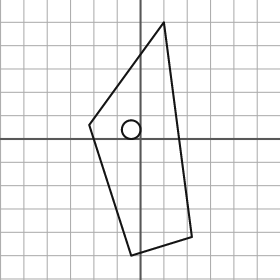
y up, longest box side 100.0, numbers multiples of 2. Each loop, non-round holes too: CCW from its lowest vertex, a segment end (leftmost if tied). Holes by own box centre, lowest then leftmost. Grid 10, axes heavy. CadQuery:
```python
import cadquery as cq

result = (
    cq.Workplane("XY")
    .moveTo(-4.0, -50.0)
    .lineTo(22.0, -42.0)
    .lineTo(10.0, 50.0)
    .lineTo(-22.0, 6.0)
    .close()
    .moveTo(-4.0, 4.0)
    .circle(4.0)
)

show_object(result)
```